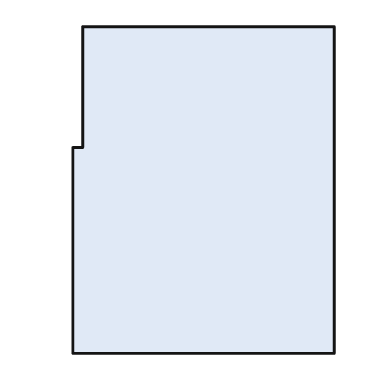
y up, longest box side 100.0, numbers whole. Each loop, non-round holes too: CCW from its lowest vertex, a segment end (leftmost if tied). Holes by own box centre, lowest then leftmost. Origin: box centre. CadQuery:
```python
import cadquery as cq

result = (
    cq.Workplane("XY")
    .moveTo(-40.0, -50.0)
    .lineTo(40.0, -50.0)
    .lineTo(40.0, 50.0)
    .lineTo(-37.0, 50.0)
    .lineTo(-37.0, 13.0)
    .lineTo(-40.0, 13.0)
    .close()
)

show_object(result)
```